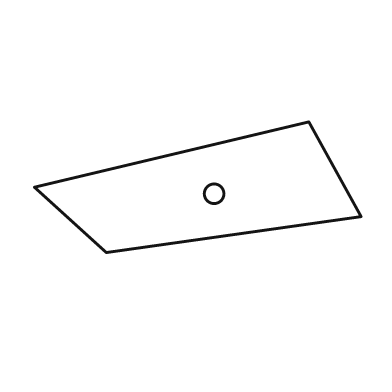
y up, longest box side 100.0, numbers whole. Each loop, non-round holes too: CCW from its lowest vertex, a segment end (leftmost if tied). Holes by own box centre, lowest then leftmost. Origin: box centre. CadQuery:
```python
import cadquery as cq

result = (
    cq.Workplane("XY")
    .moveTo(-28.0, -20.0)
    .lineTo(50.0, -9.0)
    .lineTo(34.0, 20.0)
    .lineTo(-50.0, 0.0)
    .close()
    .moveTo(5.0, -2.0)
    .circle(3.0)
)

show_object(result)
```